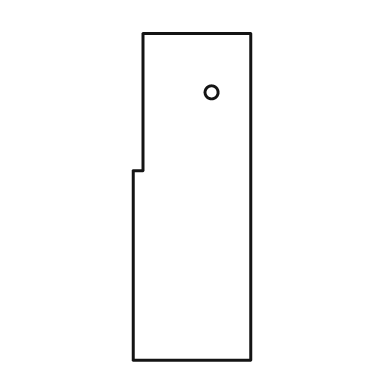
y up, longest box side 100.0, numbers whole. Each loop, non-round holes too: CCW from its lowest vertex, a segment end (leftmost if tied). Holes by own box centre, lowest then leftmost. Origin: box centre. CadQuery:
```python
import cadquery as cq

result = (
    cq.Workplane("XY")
    .moveTo(-18.0, -50.0)
    .lineTo(18.0, -50.0)
    .lineTo(18.0, 50.0)
    .lineTo(-15.0, 50.0)
    .lineTo(-15.0, 8.0)
    .lineTo(-18.0, 8.0)
    .close()
    .moveTo(6.0, 32.0)
    .circle(2.0)
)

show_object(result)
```